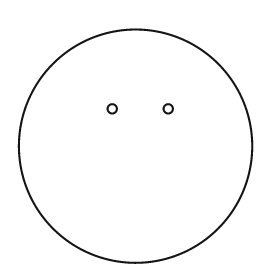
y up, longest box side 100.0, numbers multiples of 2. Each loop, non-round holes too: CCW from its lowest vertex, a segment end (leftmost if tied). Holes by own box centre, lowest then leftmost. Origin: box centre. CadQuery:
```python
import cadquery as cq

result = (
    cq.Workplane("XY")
    .moveTo(0.0, 0.0)
    .circle(50.0)
    .moveTo(-10.0, 16.0)
    .circle(2.0)
    .moveTo(14.0, 16.0)
    .circle(2.0)
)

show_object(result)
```